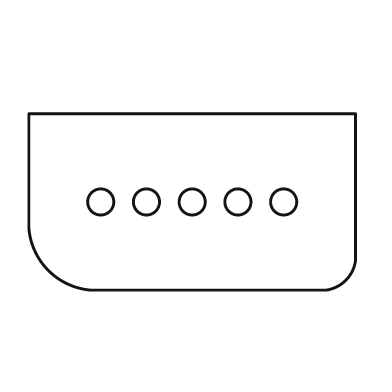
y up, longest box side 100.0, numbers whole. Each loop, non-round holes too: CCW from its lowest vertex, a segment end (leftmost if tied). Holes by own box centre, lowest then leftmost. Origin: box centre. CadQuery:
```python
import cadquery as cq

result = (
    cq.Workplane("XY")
    .moveTo(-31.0, -27.0)
    .lineTo(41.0, -27.0)
    .threePointArc((47.0, -24.0), (50.0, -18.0))
    .lineTo(50.0, 27.0)
    .lineTo(-50.0, 27.0)
    .lineTo(-50.0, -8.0)
    .threePointArc((-44.0, -21.0), (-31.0, -27.0))
    .close()
    .moveTo(-28.0, 0.0)
    .circle(4.0)
    .moveTo(-14.0, 0.0)
    .circle(4.0)
    .moveTo(0.0, 0.0)
    .circle(4.0)
    .moveTo(14.0, 0.0)
    .circle(4.0)
    .moveTo(28.0, 0.0)
    .circle(4.0)
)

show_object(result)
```